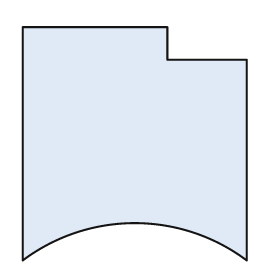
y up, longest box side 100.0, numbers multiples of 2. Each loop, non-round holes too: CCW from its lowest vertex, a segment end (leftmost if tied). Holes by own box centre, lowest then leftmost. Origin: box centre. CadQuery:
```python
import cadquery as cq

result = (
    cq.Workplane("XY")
    .moveTo(-48.0, -50.0)
    .threePointArc((0.0, -34.0), (48.0, -50.0))
    .lineTo(48.0, 36.0)
    .lineTo(14.0, 36.0)
    .lineTo(14.0, 50.0)
    .lineTo(-48.0, 50.0)
    .close()
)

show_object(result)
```